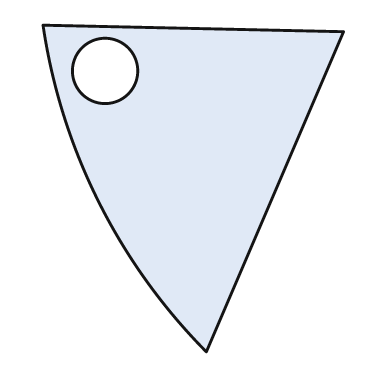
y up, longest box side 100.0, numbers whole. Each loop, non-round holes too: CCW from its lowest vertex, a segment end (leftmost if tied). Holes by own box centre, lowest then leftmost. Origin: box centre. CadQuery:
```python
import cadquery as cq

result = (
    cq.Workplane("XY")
    .moveTo(4.0, -50.0)
    .lineTo(46.0, 48.0)
    .lineTo(-46.0, 50.0)
    .threePointArc((-29.0, -4.0), (4.0, -50.0))
    .close()
    .moveTo(-27.0, 36.0)
    .circle(10.0)
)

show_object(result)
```